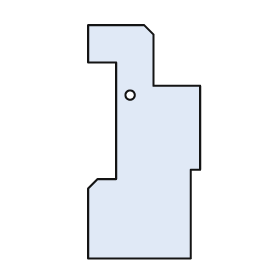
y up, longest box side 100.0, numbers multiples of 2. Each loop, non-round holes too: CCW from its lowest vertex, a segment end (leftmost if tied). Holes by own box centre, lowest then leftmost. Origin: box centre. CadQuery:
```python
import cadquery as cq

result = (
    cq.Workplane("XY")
    .moveTo(-24.0, -50.0)
    .lineTo(20.0, -50.0)
    .lineTo(20.0, -12.0)
    .lineTo(24.0, -12.0)
    .lineTo(24.0, 24.0)
    .lineTo(4.0, 24.0)
    .lineTo(4.0, 46.0)
    .lineTo(0.0, 50.0)
    .lineTo(-24.0, 50.0)
    .lineTo(-24.0, 34.0)
    .lineTo(-12.0, 34.0)
    .lineTo(-12.0, -16.0)
    .lineTo(-20.0, -16.0)
    .lineTo(-24.0, -20.0)
    .close()
    .moveTo(-6.0, 20.0)
    .circle(2.0)
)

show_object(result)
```